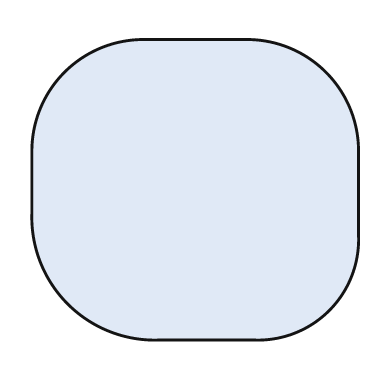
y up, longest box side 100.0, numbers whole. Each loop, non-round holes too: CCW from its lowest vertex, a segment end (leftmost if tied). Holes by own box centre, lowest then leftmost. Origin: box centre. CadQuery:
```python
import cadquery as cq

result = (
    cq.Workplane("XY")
    .moveTo(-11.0, -46.0)
    .lineTo(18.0, -46.0)
    .threePointArc((41.0, -37.0), (50.0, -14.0))
    .lineTo(50.0, 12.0)
    .threePointArc((40.0, 36.0), (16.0, 46.0))
    .lineTo(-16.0, 46.0)
    .threePointArc((-40.0, 36.0), (-50.0, 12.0))
    .lineTo(-50.0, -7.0)
    .threePointArc((-39.0, -35.0), (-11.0, -46.0))
    .close()
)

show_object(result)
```